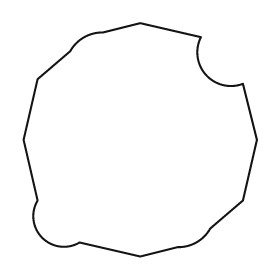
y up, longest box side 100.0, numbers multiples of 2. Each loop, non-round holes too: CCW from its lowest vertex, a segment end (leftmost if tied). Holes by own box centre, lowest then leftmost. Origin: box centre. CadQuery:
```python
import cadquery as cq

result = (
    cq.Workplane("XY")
    .moveTo(0.0, -50.0)
    .lineTo(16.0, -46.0)
    .threePointArc((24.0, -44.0), (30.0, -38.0))
    .lineTo(44.0, -26.0)
    .lineTo(50.0, 0.0)
    .lineTo(44.0, 24.0)
    .threePointArc((28.0, 28.0), (26.0, 44.0))
    .lineTo(0.0, 50.0)
    .lineTo(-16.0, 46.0)
    .threePointArc((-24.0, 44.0), (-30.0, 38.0))
    .lineTo(-44.0, 26.0)
    .lineTo(-50.0, 0.0)
    .lineTo(-44.0, -26.0)
    .threePointArc((-42.0, -42.0), (-26.0, -44.0))
    .close()
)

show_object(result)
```